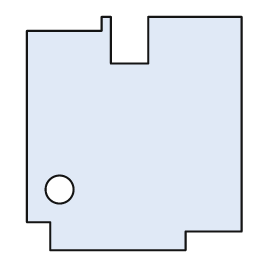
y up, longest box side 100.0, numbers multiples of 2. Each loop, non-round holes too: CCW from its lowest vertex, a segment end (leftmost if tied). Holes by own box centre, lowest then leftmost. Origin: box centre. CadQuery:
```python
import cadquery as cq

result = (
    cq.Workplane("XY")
    .moveTo(-36.0, -50.0)
    .lineTo(22.0, -50.0)
    .lineTo(22.0, -42.0)
    .lineTo(46.0, -42.0)
    .lineTo(46.0, 50.0)
    .lineTo(6.0, 50.0)
    .lineTo(6.0, 30.0)
    .lineTo(-10.0, 30.0)
    .lineTo(-10.0, 50.0)
    .lineTo(-14.0, 50.0)
    .lineTo(-14.0, 44.0)
    .lineTo(-46.0, 44.0)
    .lineTo(-46.0, -38.0)
    .lineTo(-36.0, -38.0)
    .close()
    .moveTo(-32.0, -24.0)
    .circle(6.0)
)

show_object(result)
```